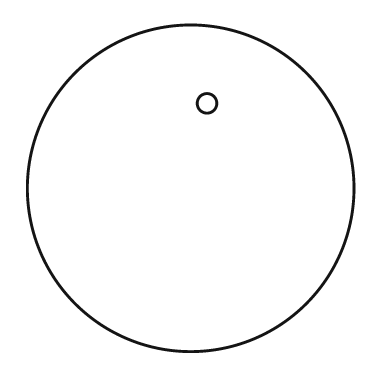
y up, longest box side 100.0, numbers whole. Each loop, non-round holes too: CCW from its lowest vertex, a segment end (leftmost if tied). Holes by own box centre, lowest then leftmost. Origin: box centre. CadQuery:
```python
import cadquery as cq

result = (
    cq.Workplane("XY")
    .moveTo(0.0, 0.0)
    .circle(50.0)
    .moveTo(5.0, 26.0)
    .circle(3.0)
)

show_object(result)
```